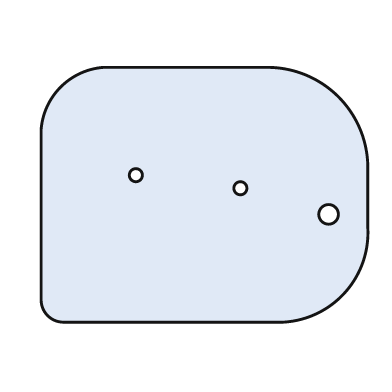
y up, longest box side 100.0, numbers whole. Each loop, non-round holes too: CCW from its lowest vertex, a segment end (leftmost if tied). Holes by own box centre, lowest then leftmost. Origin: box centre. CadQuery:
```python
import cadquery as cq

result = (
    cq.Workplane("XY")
    .moveTo(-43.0, -39.0)
    .lineTo(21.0, -39.0)
    .threePointArc((42.0, -31.0), (50.0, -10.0))
    .lineTo(50.0, 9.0)
    .threePointArc((41.0, 30.0), (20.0, 39.0))
    .lineTo(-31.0, 39.0)
    .threePointArc((-44.0, 33.0), (-50.0, 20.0))
    .lineTo(-50.0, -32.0)
    .threePointArc((-48.0, -37.0), (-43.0, -39.0))
    .close()
    .moveTo(38.0, -6.0)
    .circle(3.0)
    .moveTo(11.0, 2.0)
    .circle(2.0)
    .moveTo(-21.0, 6.0)
    .circle(2.0)
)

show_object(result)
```